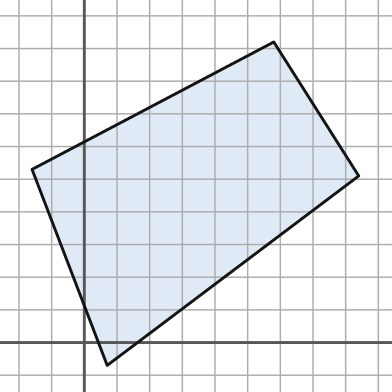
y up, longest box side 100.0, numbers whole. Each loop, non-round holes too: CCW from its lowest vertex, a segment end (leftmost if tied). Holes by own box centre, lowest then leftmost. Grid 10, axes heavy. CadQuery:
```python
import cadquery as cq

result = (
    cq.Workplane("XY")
    .moveTo(7.0, -7.0)
    .lineTo(84.0, 51.0)
    .lineTo(58.0, 92.0)
    .lineTo(-16.0, 53.0)
    .close()
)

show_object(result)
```